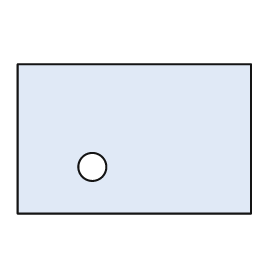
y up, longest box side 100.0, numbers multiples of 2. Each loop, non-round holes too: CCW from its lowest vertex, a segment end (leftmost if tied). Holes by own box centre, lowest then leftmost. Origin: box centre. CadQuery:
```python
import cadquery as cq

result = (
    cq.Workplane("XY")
    .moveTo(-50.0, -32.0)
    .lineTo(50.0, -32.0)
    .lineTo(50.0, 32.0)
    .lineTo(-50.0, 32.0)
    .close()
    .moveTo(-18.0, -12.0)
    .circle(6.0)
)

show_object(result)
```